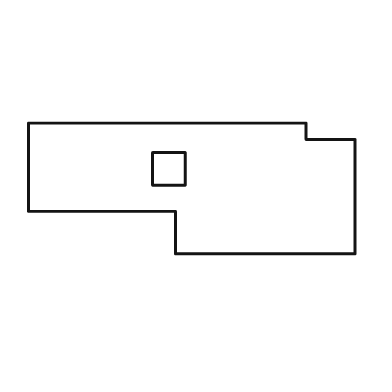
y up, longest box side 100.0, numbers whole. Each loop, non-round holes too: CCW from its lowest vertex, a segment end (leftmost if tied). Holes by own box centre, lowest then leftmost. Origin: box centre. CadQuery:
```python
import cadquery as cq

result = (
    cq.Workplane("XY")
    .moveTo(-5.0, -20.0)
    .lineTo(50.0, -20.0)
    .lineTo(50.0, 15.0)
    .lineTo(35.0, 15.0)
    .lineTo(35.0, 20.0)
    .lineTo(-50.0, 20.0)
    .lineTo(-50.0, -7.0)
    .lineTo(-5.0, -7.0)
    .close()
    .moveTo(-12.0, 1.0)
    .lineTo(-2.0, 1.0)
    .lineTo(-2.0, 11.0)
    .lineTo(-12.0, 11.0)
    .close()
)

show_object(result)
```